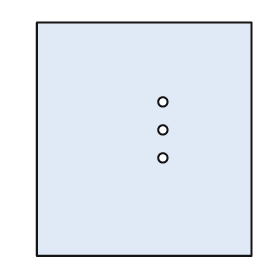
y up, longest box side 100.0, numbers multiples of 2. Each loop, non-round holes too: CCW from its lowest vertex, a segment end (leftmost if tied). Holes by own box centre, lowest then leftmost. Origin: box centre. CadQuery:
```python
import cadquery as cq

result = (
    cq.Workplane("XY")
    .moveTo(-46.0, -50.0)
    .lineTo(46.0, -50.0)
    .lineTo(46.0, 50.0)
    .lineTo(-46.0, 50.0)
    .close()
    .moveTo(8.0, -8.0)
    .circle(2.0)
    .moveTo(8.0, 4.0)
    .circle(2.0)
    .moveTo(8.0, 16.0)
    .circle(2.0)
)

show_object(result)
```